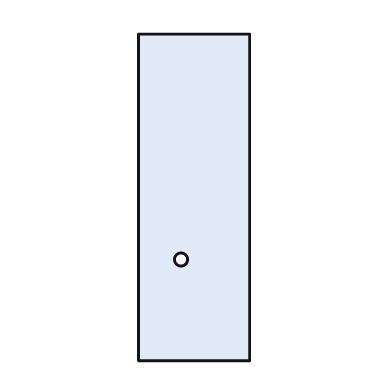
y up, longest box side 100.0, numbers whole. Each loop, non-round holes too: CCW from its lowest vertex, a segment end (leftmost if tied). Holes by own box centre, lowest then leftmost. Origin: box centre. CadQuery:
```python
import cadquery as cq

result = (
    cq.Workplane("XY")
    .moveTo(-17.0, -50.0)
    .lineTo(17.0, -50.0)
    .lineTo(17.0, 50.0)
    .lineTo(-17.0, 50.0)
    .close()
    .moveTo(-4.0, -19.0)
    .circle(2.0)
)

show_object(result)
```